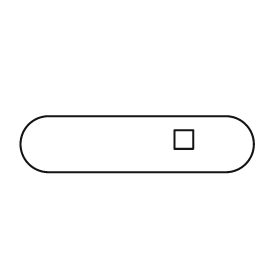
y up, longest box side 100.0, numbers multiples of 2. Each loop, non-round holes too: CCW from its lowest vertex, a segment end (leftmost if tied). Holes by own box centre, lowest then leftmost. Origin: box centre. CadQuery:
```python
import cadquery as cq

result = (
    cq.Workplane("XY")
    .moveTo(-38.0, -12.0)
    .lineTo(38.0, -12.0)
    .threePointArc((50.0, 0.0), (38.0, 12.0))
    .lineTo(-38.0, 12.0)
    .threePointArc((-50.0, 0.0), (-38.0, -12.0))
    .close()
    .moveTo(16.0, -2.0)
    .lineTo(24.0, -2.0)
    .lineTo(24.0, 6.0)
    .lineTo(16.0, 6.0)
    .close()
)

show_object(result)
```